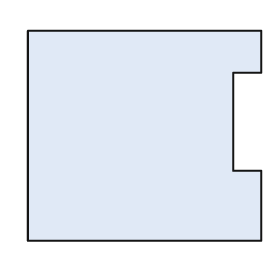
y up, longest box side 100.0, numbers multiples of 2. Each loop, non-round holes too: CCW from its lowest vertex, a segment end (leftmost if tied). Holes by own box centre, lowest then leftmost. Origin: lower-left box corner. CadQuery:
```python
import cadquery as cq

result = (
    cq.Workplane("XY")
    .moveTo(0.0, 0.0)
    .lineTo(100.0, 0.0)
    .lineTo(100.0, 30.0)
    .lineTo(88.0, 30.0)
    .lineTo(88.0, 72.0)
    .lineTo(100.0, 72.0)
    .lineTo(100.0, 90.0)
    .lineTo(0.0, 90.0)
    .close()
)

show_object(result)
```